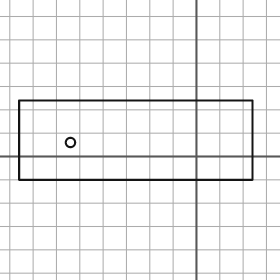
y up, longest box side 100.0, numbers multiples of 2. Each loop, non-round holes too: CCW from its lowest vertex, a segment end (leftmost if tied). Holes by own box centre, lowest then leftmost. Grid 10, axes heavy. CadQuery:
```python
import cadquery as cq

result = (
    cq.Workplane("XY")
    .moveTo(-76.0, -10.0)
    .lineTo(24.0, -10.0)
    .lineTo(24.0, 24.0)
    .lineTo(-76.0, 24.0)
    .close()
    .moveTo(-54.0, 6.0)
    .circle(2.0)
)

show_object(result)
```